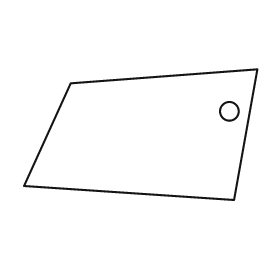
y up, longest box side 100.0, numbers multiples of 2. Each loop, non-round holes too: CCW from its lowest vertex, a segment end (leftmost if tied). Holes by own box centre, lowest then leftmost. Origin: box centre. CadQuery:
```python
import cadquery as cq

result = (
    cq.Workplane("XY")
    .moveTo(40.0, -28.0)
    .lineTo(50.0, 28.0)
    .lineTo(-30.0, 22.0)
    .lineTo(-50.0, -22.0)
    .close()
    .moveTo(38.0, 10.0)
    .circle(4.0)
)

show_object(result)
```